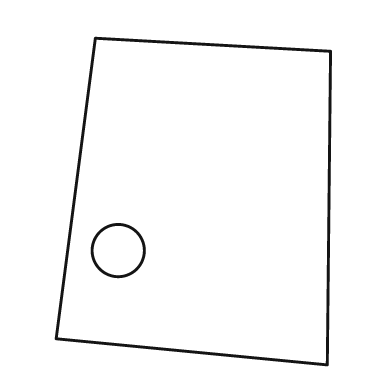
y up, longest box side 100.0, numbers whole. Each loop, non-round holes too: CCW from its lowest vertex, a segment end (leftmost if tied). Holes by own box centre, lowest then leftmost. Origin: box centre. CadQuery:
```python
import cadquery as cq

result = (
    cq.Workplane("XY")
    .moveTo(41.0, -50.0)
    .lineTo(42.0, 46.0)
    .lineTo(-30.0, 50.0)
    .lineTo(-42.0, -42.0)
    .close()
    .moveTo(-23.0, -15.0)
    .circle(8.0)
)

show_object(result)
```